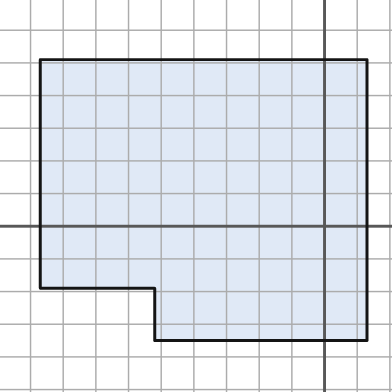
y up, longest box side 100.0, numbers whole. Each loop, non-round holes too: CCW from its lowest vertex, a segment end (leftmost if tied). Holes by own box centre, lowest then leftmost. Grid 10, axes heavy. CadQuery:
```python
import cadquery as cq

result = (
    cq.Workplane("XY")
    .moveTo(-52.0, -35.0)
    .lineTo(13.0, -35.0)
    .lineTo(13.0, 51.0)
    .lineTo(-87.0, 51.0)
    .lineTo(-87.0, -19.0)
    .lineTo(-52.0, -19.0)
    .close()
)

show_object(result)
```